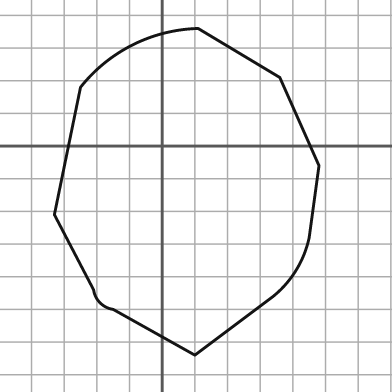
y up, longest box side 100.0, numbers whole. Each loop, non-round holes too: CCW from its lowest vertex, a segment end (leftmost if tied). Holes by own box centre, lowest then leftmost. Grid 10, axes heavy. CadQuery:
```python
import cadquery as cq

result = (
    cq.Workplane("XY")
    .moveTo(10.0, -64.0)
    .lineTo(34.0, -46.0)
    .threePointArc((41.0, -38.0), (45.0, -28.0))
    .lineTo(48.0, -6.0)
    .lineTo(36.0, 21.0)
    .lineTo(11.0, 36.0)
    .threePointArc((-9.0, 31.0), (-25.0, 18.0))
    .lineTo(-33.0, -21.0)
    .lineTo(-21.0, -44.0)
    .threePointArc((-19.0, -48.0), (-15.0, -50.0))
    .close()
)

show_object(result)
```